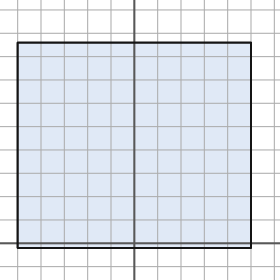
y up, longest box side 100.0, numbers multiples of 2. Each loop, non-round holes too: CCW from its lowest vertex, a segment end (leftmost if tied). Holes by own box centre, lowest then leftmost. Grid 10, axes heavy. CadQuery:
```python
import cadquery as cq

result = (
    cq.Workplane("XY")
    .moveTo(-50.0, -2.0)
    .lineTo(50.0, -2.0)
    .lineTo(50.0, 86.0)
    .lineTo(-50.0, 86.0)
    .close()
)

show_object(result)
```